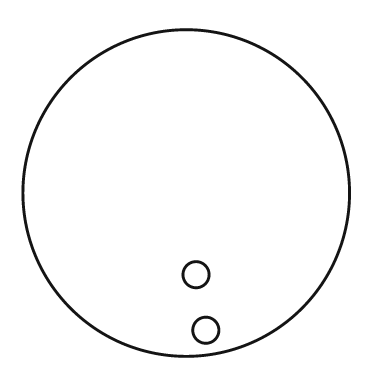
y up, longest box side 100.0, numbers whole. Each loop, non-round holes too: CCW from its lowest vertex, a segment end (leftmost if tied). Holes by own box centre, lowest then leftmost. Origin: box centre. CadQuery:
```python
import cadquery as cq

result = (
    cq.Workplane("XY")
    .moveTo(0.0, 0.0)
    .circle(50.0)
    .moveTo(6.0, -42.0)
    .circle(4.0)
    .moveTo(3.0, -25.0)
    .circle(4.0)
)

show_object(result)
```